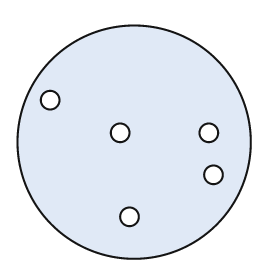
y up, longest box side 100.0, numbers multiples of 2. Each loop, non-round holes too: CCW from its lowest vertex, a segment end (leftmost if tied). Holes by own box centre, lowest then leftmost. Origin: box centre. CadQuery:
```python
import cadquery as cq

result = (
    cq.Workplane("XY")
    .moveTo(0.0, 0.0)
    .circle(50.0)
    .moveTo(-2.0, -32.0)
    .circle(4.0)
    .moveTo(34.0, -14.0)
    .circle(4.0)
    .moveTo(-6.0, 4.0)
    .circle(4.0)
    .moveTo(32.0, 4.0)
    .circle(4.0)
    .moveTo(-36.0, 18.0)
    .circle(4.0)
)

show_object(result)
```